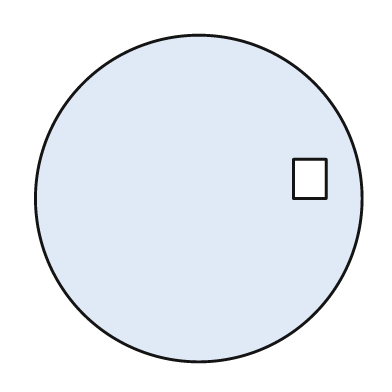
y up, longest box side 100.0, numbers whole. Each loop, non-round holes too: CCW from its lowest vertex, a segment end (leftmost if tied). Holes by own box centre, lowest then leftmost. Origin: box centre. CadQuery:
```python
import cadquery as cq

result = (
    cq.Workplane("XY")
    .moveTo(0.0, 0.0)
    .circle(50.0)
    .moveTo(29.0, 0.0)
    .lineTo(39.0, 0.0)
    .lineTo(39.0, 12.0)
    .lineTo(29.0, 12.0)
    .close()
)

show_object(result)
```